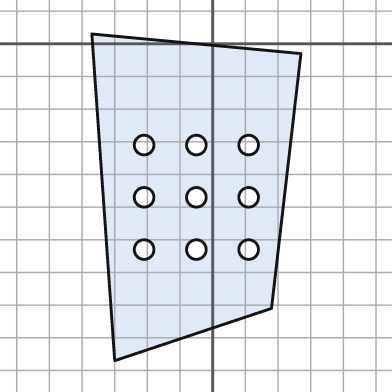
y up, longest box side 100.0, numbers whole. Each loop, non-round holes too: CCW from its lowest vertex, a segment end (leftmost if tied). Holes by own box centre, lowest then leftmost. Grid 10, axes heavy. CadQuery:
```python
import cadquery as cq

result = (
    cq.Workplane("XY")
    .moveTo(-30.0, -97.0)
    .lineTo(18.0, -81.0)
    .lineTo(27.0, -3.0)
    .lineTo(-37.0, 3.0)
    .close()
    .moveTo(-21.0, -63.0)
    .circle(3.0)
    .moveTo(-5.0, -63.0)
    .circle(3.0)
    .moveTo(11.0, -63.0)
    .circle(3.0)
    .moveTo(-21.0, -47.0)
    .circle(3.0)
    .moveTo(-5.0, -47.0)
    .circle(3.0)
    .moveTo(11.0, -47.0)
    .circle(3.0)
    .moveTo(-21.0, -31.0)
    .circle(3.0)
    .moveTo(-5.0, -31.0)
    .circle(3.0)
    .moveTo(11.0, -31.0)
    .circle(3.0)
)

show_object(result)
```